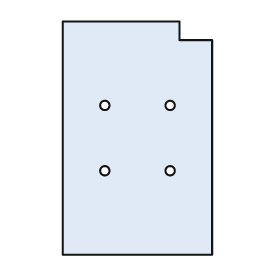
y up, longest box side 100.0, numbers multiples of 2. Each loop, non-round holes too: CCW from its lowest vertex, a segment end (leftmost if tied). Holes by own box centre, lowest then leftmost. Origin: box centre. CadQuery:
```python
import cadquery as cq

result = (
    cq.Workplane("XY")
    .moveTo(-32.0, -50.0)
    .lineTo(32.0, -50.0)
    .lineTo(32.0, 42.0)
    .lineTo(18.0, 42.0)
    .lineTo(18.0, 50.0)
    .lineTo(-32.0, 50.0)
    .close()
    .moveTo(-14.0, -14.0)
    .circle(2.0)
    .moveTo(14.0, -14.0)
    .circle(2.0)
    .moveTo(-14.0, 14.0)
    .circle(2.0)
    .moveTo(14.0, 14.0)
    .circle(2.0)
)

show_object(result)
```